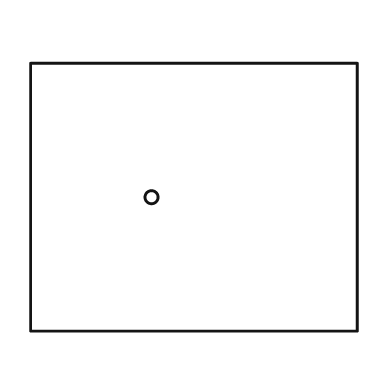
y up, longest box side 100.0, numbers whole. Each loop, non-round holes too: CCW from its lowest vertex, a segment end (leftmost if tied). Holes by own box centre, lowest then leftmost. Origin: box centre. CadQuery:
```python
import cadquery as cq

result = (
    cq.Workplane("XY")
    .moveTo(-50.0, -41.0)
    .lineTo(50.0, -41.0)
    .lineTo(50.0, 41.0)
    .lineTo(-50.0, 41.0)
    .close()
    .moveTo(-13.0, 0.0)
    .circle(2.0)
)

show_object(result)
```